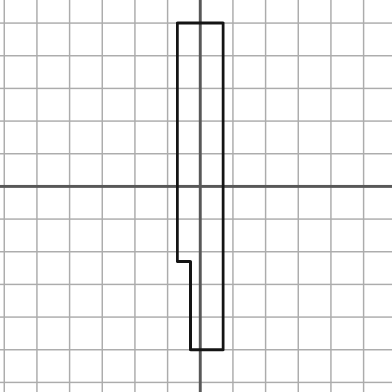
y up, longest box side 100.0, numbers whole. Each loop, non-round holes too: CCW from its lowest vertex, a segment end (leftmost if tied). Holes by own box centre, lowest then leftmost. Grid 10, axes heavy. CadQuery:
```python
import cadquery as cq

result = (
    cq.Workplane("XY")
    .moveTo(-3.0, -50.0)
    .lineTo(7.0, -50.0)
    .lineTo(7.0, 50.0)
    .lineTo(-7.0, 50.0)
    .lineTo(-7.0, -23.0)
    .lineTo(-3.0, -23.0)
    .close()
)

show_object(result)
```